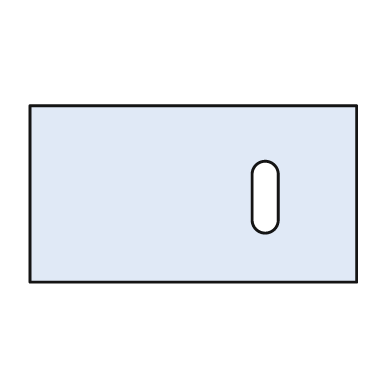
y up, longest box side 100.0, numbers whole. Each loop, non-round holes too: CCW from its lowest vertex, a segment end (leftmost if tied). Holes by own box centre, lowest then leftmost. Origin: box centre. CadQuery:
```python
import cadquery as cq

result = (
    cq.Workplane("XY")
    .moveTo(-50.0, -27.0)
    .lineTo(50.0, -27.0)
    .lineTo(50.0, 27.0)
    .lineTo(-50.0, 27.0)
    .close()
    .moveTo(18.0, -8.0)
    .threePointArc((22.0, -12.0), (26.0, -8.0))
    .lineTo(26.0, 6.0)
    .threePointArc((22.0, 10.0), (18.0, 6.0))
    .close()
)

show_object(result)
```